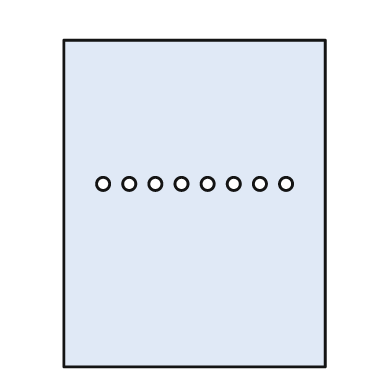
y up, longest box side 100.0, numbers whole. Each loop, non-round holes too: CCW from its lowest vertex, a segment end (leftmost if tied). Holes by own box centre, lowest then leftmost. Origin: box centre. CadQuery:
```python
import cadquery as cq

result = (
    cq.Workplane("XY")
    .moveTo(-40.0, -50.0)
    .lineTo(40.0, -50.0)
    .lineTo(40.0, 50.0)
    .lineTo(-40.0, 50.0)
    .close()
    .moveTo(-28.0, 6.0)
    .circle(2.0)
    .moveTo(-20.0, 6.0)
    .circle(2.0)
    .moveTo(-12.0, 6.0)
    .circle(2.0)
    .moveTo(-4.0, 6.0)
    .circle(2.0)
    .moveTo(4.0, 6.0)
    .circle(2.0)
    .moveTo(12.0, 6.0)
    .circle(2.0)
    .moveTo(20.0, 6.0)
    .circle(2.0)
    .moveTo(28.0, 6.0)
    .circle(2.0)
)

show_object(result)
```